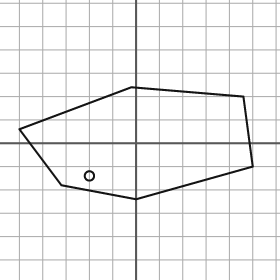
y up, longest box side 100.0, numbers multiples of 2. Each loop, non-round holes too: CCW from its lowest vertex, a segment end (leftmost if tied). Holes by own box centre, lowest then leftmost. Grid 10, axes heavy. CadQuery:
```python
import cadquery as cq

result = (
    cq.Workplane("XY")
    .moveTo(0.0, -24.0)
    .lineTo(50.0, -10.0)
    .lineTo(46.0, 20.0)
    .lineTo(-2.0, 24.0)
    .lineTo(-50.0, 6.0)
    .lineTo(-32.0, -18.0)
    .close()
    .moveTo(-20.0, -14.0)
    .circle(2.0)
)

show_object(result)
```